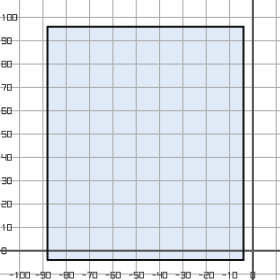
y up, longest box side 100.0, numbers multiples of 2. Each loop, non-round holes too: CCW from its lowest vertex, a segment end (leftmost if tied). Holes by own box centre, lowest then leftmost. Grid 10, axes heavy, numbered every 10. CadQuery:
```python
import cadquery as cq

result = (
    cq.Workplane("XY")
    .moveTo(-88.0, -4.0)
    .lineTo(-4.0, -4.0)
    .lineTo(-4.0, 96.0)
    .lineTo(-88.0, 96.0)
    .close()
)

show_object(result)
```